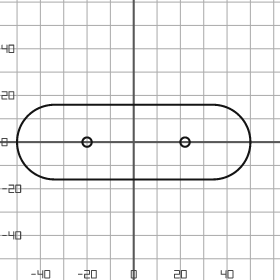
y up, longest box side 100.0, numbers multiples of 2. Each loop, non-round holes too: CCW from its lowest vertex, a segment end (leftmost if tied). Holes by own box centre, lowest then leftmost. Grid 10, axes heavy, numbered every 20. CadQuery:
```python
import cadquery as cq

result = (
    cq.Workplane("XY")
    .moveTo(-34.0, -16.0)
    .lineTo(34.0, -16.0)
    .threePointArc((50.0, 0.0), (34.0, 16.0))
    .lineTo(-34.0, 16.0)
    .threePointArc((-50.0, 0.0), (-34.0, -16.0))
    .close()
    .moveTo(-20.0, 0.0)
    .circle(2.0)
    .moveTo(22.0, 0.0)
    .circle(2.0)
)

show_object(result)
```